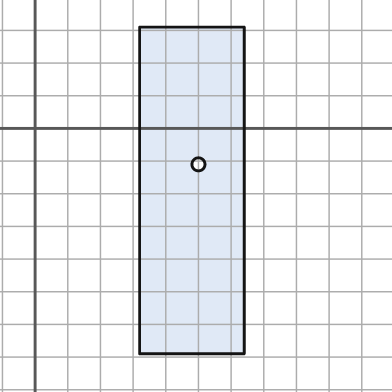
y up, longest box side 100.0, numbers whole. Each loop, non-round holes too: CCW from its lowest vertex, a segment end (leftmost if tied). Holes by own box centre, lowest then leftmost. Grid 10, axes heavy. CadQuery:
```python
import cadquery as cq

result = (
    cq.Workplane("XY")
    .moveTo(32.0, -69.0)
    .lineTo(64.0, -69.0)
    .lineTo(64.0, 31.0)
    .lineTo(32.0, 31.0)
    .close()
    .moveTo(50.0, -11.0)
    .circle(2.0)
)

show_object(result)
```